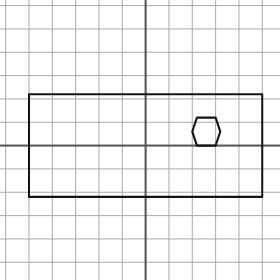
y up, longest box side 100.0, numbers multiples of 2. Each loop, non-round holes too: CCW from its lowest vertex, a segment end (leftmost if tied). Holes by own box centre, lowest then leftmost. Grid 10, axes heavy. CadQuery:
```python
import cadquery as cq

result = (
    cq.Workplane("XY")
    .moveTo(-50.0, -22.0)
    .lineTo(50.0, -22.0)
    .lineTo(50.0, 22.0)
    .lineTo(-50.0, 22.0)
    .close()
    .moveTo(22.0, 0.0)
    .lineTo(30.0, 0.0)
    .lineTo(32.0, 6.0)
    .lineTo(30.0, 12.0)
    .lineTo(22.0, 12.0)
    .lineTo(20.0, 6.0)
    .close()
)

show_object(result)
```